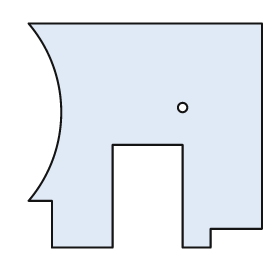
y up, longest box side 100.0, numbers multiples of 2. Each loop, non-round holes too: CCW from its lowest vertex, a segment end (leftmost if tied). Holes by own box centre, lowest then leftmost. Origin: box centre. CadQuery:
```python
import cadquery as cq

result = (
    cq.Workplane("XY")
    .moveTo(-40.0, -48.0)
    .lineTo(-14.0, -48.0)
    .lineTo(-14.0, -4.0)
    .lineTo(16.0, -4.0)
    .lineTo(16.0, -48.0)
    .lineTo(28.0, -48.0)
    .lineTo(28.0, -40.0)
    .lineTo(50.0, -40.0)
    .lineTo(50.0, 48.0)
    .lineTo(-50.0, 48.0)
    .threePointArc((-36.0, 10.0), (-50.0, -28.0))
    .lineTo(-40.0, -28.0)
    .close()
    .moveTo(16.0, 12.0)
    .circle(2.0)
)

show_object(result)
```